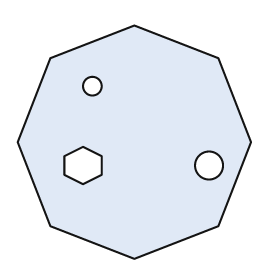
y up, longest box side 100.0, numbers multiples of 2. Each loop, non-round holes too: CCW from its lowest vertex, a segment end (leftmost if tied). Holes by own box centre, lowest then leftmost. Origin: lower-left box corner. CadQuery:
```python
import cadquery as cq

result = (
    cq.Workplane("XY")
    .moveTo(50.0, 0.0)
    .lineTo(86.0, 14.0)
    .lineTo(100.0, 50.0)
    .lineTo(86.0, 86.0)
    .lineTo(50.0, 100.0)
    .lineTo(14.0, 86.0)
    .lineTo(0.0, 50.0)
    .lineTo(14.0, 14.0)
    .close()
    .moveTo(28.0, 32.0)
    .lineTo(36.0, 36.0)
    .lineTo(36.0, 44.0)
    .lineTo(28.0, 48.0)
    .lineTo(20.0, 44.0)
    .lineTo(20.0, 36.0)
    .close()
    .moveTo(82.0, 40.0)
    .circle(6.0)
    .moveTo(32.0, 74.0)
    .circle(4.0)
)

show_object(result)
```